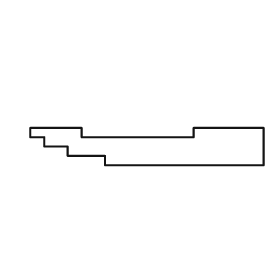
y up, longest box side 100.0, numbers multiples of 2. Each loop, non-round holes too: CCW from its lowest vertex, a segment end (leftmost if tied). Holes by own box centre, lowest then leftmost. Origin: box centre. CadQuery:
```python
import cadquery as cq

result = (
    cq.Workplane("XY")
    .moveTo(-18.0, -8.0)
    .lineTo(50.0, -8.0)
    .lineTo(50.0, 8.0)
    .lineTo(20.0, 8.0)
    .lineTo(20.0, 4.0)
    .lineTo(-28.0, 4.0)
    .lineTo(-28.0, 8.0)
    .lineTo(-50.0, 8.0)
    .lineTo(-50.0, 4.0)
    .lineTo(-44.0, 4.0)
    .lineTo(-44.0, 0.0)
    .lineTo(-34.0, 0.0)
    .lineTo(-34.0, -4.0)
    .lineTo(-18.0, -4.0)
    .close()
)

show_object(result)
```